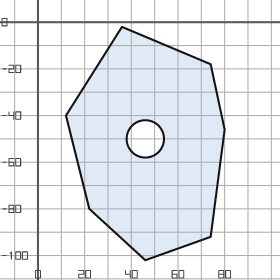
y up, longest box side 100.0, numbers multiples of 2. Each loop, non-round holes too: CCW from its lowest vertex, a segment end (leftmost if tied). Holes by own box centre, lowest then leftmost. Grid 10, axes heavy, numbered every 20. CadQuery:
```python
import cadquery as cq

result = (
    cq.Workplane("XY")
    .moveTo(46.0, -102.0)
    .lineTo(74.0, -92.0)
    .lineTo(80.0, -46.0)
    .lineTo(74.0, -18.0)
    .lineTo(36.0, -2.0)
    .lineTo(12.0, -40.0)
    .lineTo(22.0, -80.0)
    .close()
    .moveTo(46.0, -50.0)
    .circle(8.0)
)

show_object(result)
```